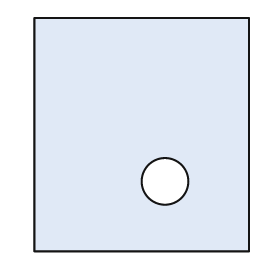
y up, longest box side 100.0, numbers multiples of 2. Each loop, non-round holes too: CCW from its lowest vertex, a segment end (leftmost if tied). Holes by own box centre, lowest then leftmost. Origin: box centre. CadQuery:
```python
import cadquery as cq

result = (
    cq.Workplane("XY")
    .moveTo(-46.0, -50.0)
    .lineTo(46.0, -50.0)
    .lineTo(46.0, 50.0)
    .lineTo(-46.0, 50.0)
    .close()
    .moveTo(10.0, -20.0)
    .circle(10.0)
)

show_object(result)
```